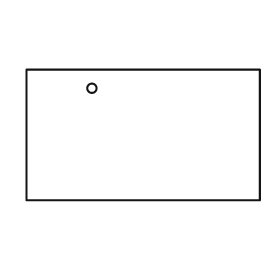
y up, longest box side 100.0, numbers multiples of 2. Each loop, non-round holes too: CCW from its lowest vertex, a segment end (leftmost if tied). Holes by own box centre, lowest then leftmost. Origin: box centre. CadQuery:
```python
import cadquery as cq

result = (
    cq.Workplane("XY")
    .moveTo(-50.0, -28.0)
    .lineTo(50.0, -28.0)
    .lineTo(50.0, 28.0)
    .lineTo(-50.0, 28.0)
    .close()
    .moveTo(-22.0, 20.0)
    .circle(2.0)
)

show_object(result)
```